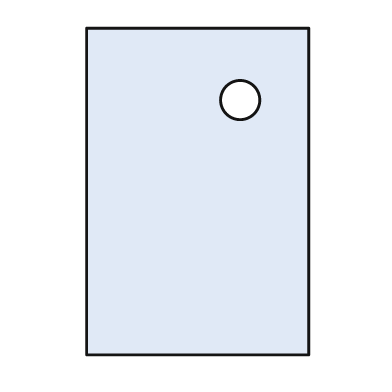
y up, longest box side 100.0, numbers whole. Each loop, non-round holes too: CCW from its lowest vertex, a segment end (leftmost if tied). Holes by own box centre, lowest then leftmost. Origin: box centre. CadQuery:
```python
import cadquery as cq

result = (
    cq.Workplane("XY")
    .moveTo(-34.0, -50.0)
    .lineTo(34.0, -50.0)
    .lineTo(34.0, 50.0)
    .lineTo(-34.0, 50.0)
    .close()
    .moveTo(13.0, 28.0)
    .circle(6.0)
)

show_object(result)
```